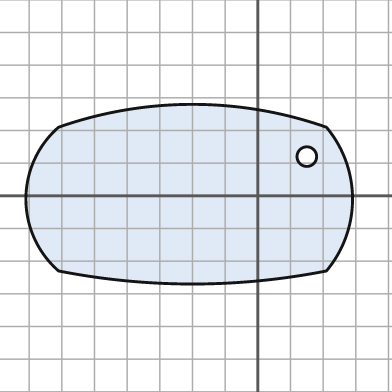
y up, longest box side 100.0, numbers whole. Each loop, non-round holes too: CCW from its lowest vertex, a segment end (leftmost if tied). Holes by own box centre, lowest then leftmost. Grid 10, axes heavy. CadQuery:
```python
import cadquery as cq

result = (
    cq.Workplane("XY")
    .moveTo(-61.0, -23.0)
    .threePointArc((-20.0, -27.0), (21.0, -23.0))
    .threePointArc((29.0, -1.0), (21.0, 21.0))
    .threePointArc((-20.0, 28.0), (-61.0, 21.0))
    .threePointArc((-71.0, -1.0), (-61.0, -23.0))
    .close()
    .moveTo(15.0, 12.0)
    .circle(3.0)
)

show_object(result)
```